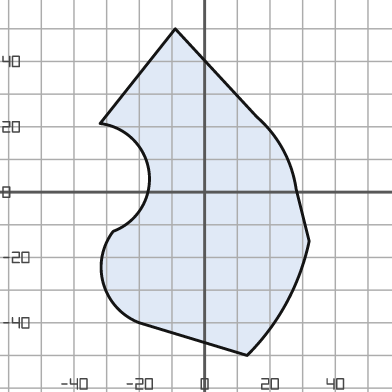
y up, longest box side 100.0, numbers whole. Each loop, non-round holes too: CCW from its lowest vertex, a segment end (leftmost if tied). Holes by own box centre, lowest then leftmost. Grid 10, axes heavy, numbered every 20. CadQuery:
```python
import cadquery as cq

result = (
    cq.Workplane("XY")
    .moveTo(13.0, -50.0)
    .threePointArc((25.0, -34.0), (32.0, -15.0))
    .lineTo(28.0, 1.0)
    .threePointArc((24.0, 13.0), (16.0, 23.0))
    .lineTo(-9.0, 50.0)
    .lineTo(-32.0, 21.0)
    .threePointArc((-17.0, 6.0), (-28.0, -12.0))
    .threePointArc((-31.0, -28.0), (-20.0, -40.0))
    .close()
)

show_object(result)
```